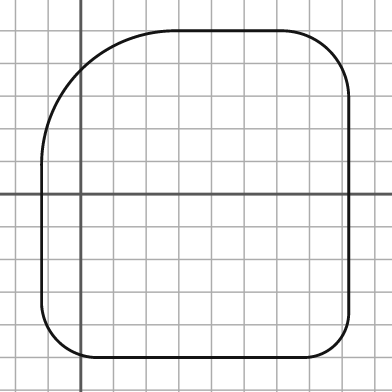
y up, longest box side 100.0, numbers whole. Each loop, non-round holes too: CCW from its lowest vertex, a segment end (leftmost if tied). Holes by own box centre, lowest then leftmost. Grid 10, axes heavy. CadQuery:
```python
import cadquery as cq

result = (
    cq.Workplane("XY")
    .moveTo(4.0, -50.0)
    .lineTo(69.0, -50.0)
    .threePointArc((78.0, -46.0), (82.0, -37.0))
    .lineTo(82.0, 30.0)
    .threePointArc((76.0, 44.0), (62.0, 50.0))
    .lineTo(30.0, 50.0)
    .threePointArc((0.0, 38.0), (-12.0, 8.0))
    .lineTo(-12.0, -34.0)
    .threePointArc((-7.0, -45.0), (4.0, -50.0))
    .close()
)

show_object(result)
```